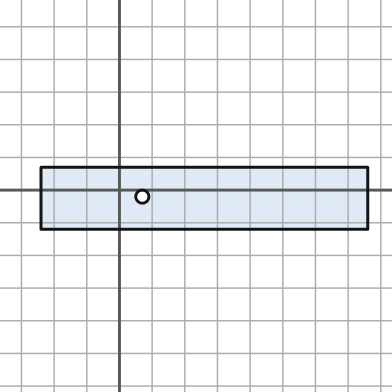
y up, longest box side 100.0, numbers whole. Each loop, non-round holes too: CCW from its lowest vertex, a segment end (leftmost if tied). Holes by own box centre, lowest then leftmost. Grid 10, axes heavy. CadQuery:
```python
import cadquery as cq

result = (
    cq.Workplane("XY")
    .moveTo(-24.0, -12.0)
    .lineTo(76.0, -12.0)
    .lineTo(76.0, 7.0)
    .lineTo(-24.0, 7.0)
    .close()
    .moveTo(7.0, -2.0)
    .circle(2.0)
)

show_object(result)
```